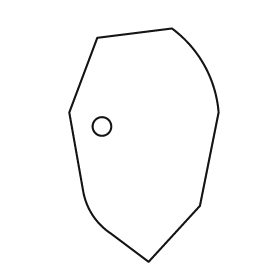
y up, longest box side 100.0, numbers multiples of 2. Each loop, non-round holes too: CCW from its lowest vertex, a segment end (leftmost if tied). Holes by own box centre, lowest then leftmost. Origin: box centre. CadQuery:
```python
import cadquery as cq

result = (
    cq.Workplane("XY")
    .moveTo(2.0, -50.0)
    .lineTo(24.0, -26.0)
    .lineTo(32.0, 14.0)
    .threePointArc((26.0, 34.0), (12.0, 50.0))
    .lineTo(-20.0, 46.0)
    .lineTo(-32.0, 14.0)
    .lineTo(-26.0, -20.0)
    .threePointArc((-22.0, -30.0), (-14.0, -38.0))
    .close()
    .moveTo(-18.0, 8.0)
    .circle(4.0)
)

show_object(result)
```